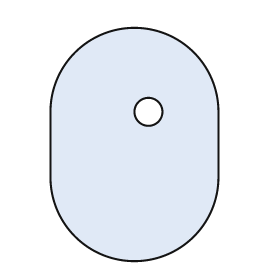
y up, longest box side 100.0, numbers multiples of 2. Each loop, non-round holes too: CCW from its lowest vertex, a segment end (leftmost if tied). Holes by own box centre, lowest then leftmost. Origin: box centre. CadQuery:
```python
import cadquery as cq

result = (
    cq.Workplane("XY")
    .moveTo(-36.0, -14.0)
    .threePointArc((0.0, -50.0), (36.0, -14.0))
    .lineTo(36.0, 14.0)
    .threePointArc((0.0, 50.0), (-36.0, 14.0))
    .close()
    .moveTo(6.0, 14.0)
    .circle(6.0)
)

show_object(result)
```